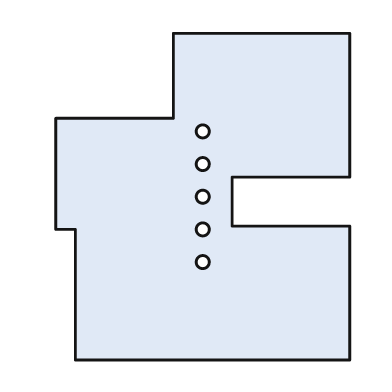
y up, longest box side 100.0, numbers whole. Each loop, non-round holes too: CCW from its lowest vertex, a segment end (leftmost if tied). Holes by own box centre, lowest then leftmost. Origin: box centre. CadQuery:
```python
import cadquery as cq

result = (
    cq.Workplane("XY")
    .moveTo(-39.0, -50.0)
    .lineTo(45.0, -50.0)
    .lineTo(45.0, -9.0)
    .lineTo(9.0, -9.0)
    .lineTo(9.0, 6.0)
    .lineTo(45.0, 6.0)
    .lineTo(45.0, 50.0)
    .lineTo(-9.0, 50.0)
    .lineTo(-9.0, 24.0)
    .lineTo(-45.0, 24.0)
    .lineTo(-45.0, -10.0)
    .lineTo(-39.0, -10.0)
    .close()
    .moveTo(0.0, -20.0)
    .circle(2.0)
    .moveTo(0.0, -10.0)
    .circle(2.0)
    .moveTo(0.0, 0.0)
    .circle(2.0)
    .moveTo(0.0, 10.0)
    .circle(2.0)
    .moveTo(0.0, 20.0)
    .circle(2.0)
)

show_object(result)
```